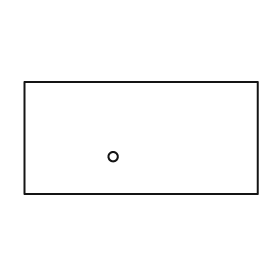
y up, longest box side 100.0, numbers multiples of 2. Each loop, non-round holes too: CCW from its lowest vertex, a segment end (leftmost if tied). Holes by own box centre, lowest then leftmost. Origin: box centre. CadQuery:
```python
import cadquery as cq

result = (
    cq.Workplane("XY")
    .moveTo(-50.0, -24.0)
    .lineTo(50.0, -24.0)
    .lineTo(50.0, 24.0)
    .lineTo(-50.0, 24.0)
    .close()
    .moveTo(-12.0, -8.0)
    .circle(2.0)
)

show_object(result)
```